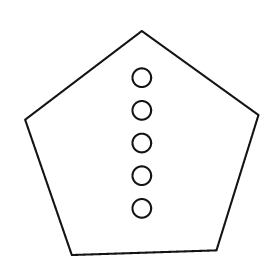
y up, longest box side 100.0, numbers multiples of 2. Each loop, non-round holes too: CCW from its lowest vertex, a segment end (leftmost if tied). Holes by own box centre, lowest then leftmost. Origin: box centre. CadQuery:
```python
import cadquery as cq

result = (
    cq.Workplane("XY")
    .moveTo(-30.0, -48.0)
    .lineTo(32.0, -46.0)
    .lineTo(50.0, 12.0)
    .lineTo(0.0, 48.0)
    .lineTo(-50.0, 10.0)
    .close()
    .moveTo(0.0, -28.0)
    .circle(4.0)
    .moveTo(0.0, -14.0)
    .circle(4.0)
    .moveTo(0.0, 0.0)
    .circle(4.0)
    .moveTo(0.0, 14.0)
    .circle(4.0)
    .moveTo(0.0, 28.0)
    .circle(4.0)
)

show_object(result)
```